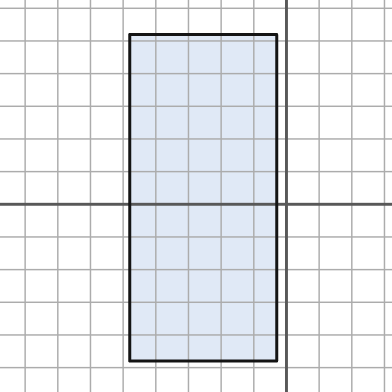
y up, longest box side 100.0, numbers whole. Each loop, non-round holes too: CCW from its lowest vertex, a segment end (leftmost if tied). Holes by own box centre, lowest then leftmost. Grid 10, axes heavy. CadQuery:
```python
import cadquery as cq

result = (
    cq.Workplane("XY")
    .moveTo(-48.0, -48.0)
    .lineTo(-3.0, -48.0)
    .lineTo(-3.0, 52.0)
    .lineTo(-48.0, 52.0)
    .close()
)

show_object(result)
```